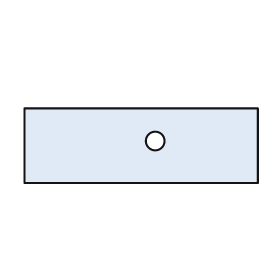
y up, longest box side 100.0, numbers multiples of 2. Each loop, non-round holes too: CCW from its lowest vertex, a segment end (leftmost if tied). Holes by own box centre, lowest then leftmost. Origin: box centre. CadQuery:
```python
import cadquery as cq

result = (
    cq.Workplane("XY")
    .moveTo(-50.0, -16.0)
    .lineTo(50.0, -16.0)
    .lineTo(50.0, 16.0)
    .lineTo(-50.0, 16.0)
    .close()
    .moveTo(6.0, 2.0)
    .circle(4.0)
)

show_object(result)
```